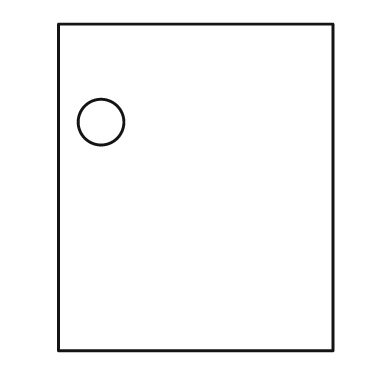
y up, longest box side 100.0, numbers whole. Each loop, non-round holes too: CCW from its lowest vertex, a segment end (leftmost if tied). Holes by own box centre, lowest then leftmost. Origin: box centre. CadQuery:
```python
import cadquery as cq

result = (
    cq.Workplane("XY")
    .moveTo(-42.0, -50.0)
    .lineTo(42.0, -50.0)
    .lineTo(42.0, 50.0)
    .lineTo(-42.0, 50.0)
    .close()
    .moveTo(-29.0, 20.0)
    .circle(7.0)
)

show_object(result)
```